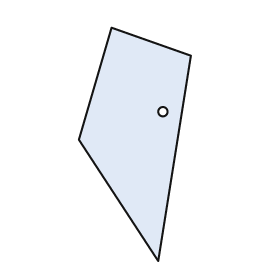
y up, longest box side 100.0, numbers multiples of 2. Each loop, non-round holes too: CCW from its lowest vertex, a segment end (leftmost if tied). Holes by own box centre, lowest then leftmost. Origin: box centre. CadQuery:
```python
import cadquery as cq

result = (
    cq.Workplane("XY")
    .moveTo(10.0, -50.0)
    .lineTo(24.0, 38.0)
    .lineTo(-10.0, 50.0)
    .lineTo(-24.0, 2.0)
    .close()
    .moveTo(12.0, 14.0)
    .circle(2.0)
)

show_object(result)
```